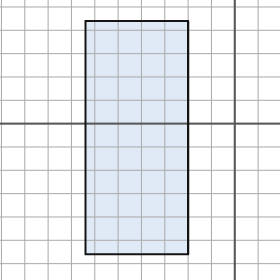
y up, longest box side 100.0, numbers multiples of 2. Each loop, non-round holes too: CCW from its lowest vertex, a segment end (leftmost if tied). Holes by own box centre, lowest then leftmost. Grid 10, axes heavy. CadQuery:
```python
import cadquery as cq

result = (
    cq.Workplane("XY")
    .moveTo(-64.0, -56.0)
    .lineTo(-20.0, -56.0)
    .lineTo(-20.0, 44.0)
    .lineTo(-64.0, 44.0)
    .close()
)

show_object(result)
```